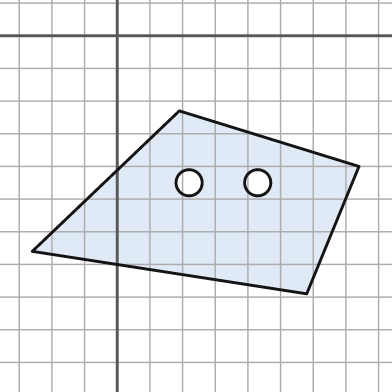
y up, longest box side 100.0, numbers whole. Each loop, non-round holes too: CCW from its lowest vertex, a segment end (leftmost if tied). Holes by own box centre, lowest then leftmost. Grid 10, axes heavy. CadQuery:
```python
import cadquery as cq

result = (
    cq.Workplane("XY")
    .moveTo(58.0, -79.0)
    .lineTo(74.0, -40.0)
    .lineTo(19.0, -23.0)
    .lineTo(-26.0, -66.0)
    .close()
    .moveTo(22.0, -45.0)
    .circle(4.0)
    .moveTo(43.0, -45.0)
    .circle(4.0)
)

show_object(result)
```